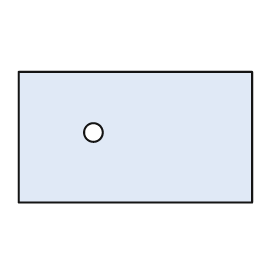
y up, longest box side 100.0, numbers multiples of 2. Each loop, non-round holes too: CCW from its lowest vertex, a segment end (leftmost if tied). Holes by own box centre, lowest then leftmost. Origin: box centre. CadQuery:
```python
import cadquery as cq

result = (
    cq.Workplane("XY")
    .moveTo(-50.0, -28.0)
    .lineTo(50.0, -28.0)
    .lineTo(50.0, 28.0)
    .lineTo(-50.0, 28.0)
    .close()
    .moveTo(-18.0, 2.0)
    .circle(4.0)
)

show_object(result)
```